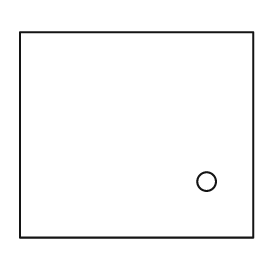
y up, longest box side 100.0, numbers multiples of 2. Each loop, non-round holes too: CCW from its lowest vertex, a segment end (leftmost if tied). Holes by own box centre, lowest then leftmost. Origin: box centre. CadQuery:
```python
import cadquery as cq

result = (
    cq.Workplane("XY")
    .moveTo(-50.0, -44.0)
    .lineTo(50.0, -44.0)
    .lineTo(50.0, 44.0)
    .lineTo(-50.0, 44.0)
    .close()
    .moveTo(30.0, -20.0)
    .circle(4.0)
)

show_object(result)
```